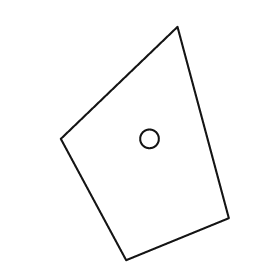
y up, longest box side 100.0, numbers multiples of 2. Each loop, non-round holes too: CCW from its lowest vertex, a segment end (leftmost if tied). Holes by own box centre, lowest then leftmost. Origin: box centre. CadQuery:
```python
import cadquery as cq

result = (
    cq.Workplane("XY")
    .moveTo(-8.0, -50.0)
    .lineTo(36.0, -32.0)
    .lineTo(14.0, 50.0)
    .lineTo(-36.0, 2.0)
    .close()
    .moveTo(2.0, 2.0)
    .circle(4.0)
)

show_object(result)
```